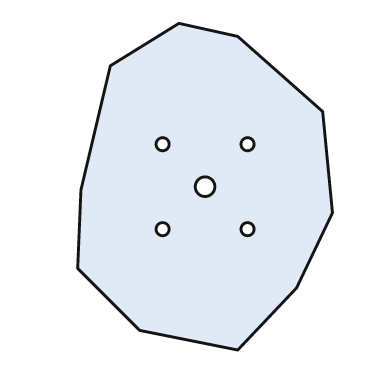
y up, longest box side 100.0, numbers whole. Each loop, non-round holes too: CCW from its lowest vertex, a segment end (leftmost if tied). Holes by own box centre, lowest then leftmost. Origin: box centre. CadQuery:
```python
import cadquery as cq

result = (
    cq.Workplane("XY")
    .moveTo(10.0, -50.0)
    .lineTo(28.0, -31.0)
    .lineTo(39.0, -8.0)
    .lineTo(36.0, 23.0)
    .lineTo(10.0, 46.0)
    .lineTo(-8.0, 50.0)
    .lineTo(-29.0, 37.0)
    .lineTo(-38.0, -1.0)
    .lineTo(-39.0, -25.0)
    .lineTo(-20.0, -44.0)
    .close()
    .moveTo(-13.0, -13.0)
    .circle(2.0)
    .moveTo(13.0, -13.0)
    .circle(2.0)
    .moveTo(0.0, 0.0)
    .circle(3.0)
    .moveTo(-13.0, 13.0)
    .circle(2.0)
    .moveTo(13.0, 13.0)
    .circle(2.0)
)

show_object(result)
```